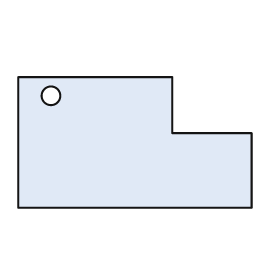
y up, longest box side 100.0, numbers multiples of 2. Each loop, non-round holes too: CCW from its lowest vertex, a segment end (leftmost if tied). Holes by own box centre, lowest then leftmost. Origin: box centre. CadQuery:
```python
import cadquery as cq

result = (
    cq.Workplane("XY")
    .moveTo(-50.0, -28.0)
    .lineTo(50.0, -28.0)
    .lineTo(50.0, 4.0)
    .lineTo(16.0, 4.0)
    .lineTo(16.0, 28.0)
    .lineTo(-50.0, 28.0)
    .close()
    .moveTo(-36.0, 20.0)
    .circle(4.0)
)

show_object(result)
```